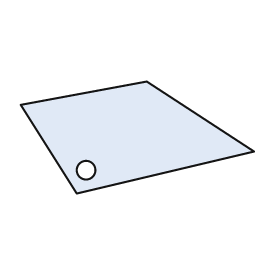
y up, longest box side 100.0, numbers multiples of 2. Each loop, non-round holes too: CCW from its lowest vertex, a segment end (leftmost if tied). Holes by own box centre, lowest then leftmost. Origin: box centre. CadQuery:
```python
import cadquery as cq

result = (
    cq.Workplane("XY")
    .moveTo(-26.0, -24.0)
    .lineTo(50.0, -6.0)
    .lineTo(4.0, 24.0)
    .lineTo(-50.0, 14.0)
    .close()
    .moveTo(-22.0, -14.0)
    .circle(4.0)
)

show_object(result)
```